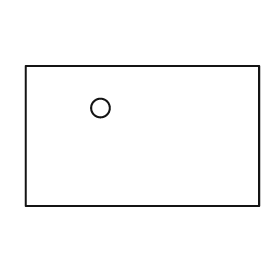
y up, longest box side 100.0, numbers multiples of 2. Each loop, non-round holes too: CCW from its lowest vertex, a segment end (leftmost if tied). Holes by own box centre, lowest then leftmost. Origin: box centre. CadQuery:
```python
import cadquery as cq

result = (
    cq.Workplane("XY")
    .moveTo(-50.0, -30.0)
    .lineTo(50.0, -30.0)
    .lineTo(50.0, 30.0)
    .lineTo(-50.0, 30.0)
    .close()
    .moveTo(-18.0, 12.0)
    .circle(4.0)
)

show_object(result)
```